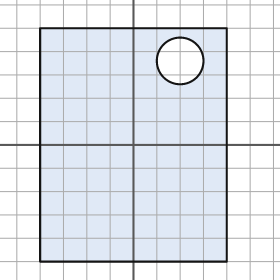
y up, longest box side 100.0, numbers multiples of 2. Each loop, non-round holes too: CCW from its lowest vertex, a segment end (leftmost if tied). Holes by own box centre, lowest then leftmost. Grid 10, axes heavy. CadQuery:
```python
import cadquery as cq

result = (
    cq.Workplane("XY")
    .moveTo(-40.0, -50.0)
    .lineTo(40.0, -50.0)
    .lineTo(40.0, 50.0)
    .lineTo(-40.0, 50.0)
    .close()
    .moveTo(20.0, 36.0)
    .circle(10.0)
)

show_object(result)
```